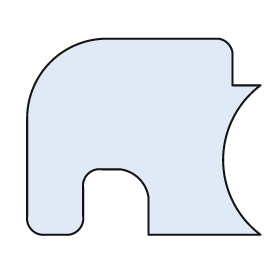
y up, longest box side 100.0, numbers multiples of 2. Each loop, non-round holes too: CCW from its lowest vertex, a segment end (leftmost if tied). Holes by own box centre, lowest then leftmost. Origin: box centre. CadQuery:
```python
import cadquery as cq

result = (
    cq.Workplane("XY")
    .moveTo(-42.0, -42.0)
    .lineTo(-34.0, -42.0)
    .threePointArc((-28.0, -40.0), (-26.0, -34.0))
    .lineTo(-26.0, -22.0)
    .threePointArc((-24.0, -16.0), (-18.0, -14.0))
    .lineTo(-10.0, -14.0)
    .threePointArc((-2.0, -18.0), (2.0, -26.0))
    .lineTo(2.0, -42.0)
    .lineTo(50.0, -42.0)
    .threePointArc((34.0, -10.0), (50.0, 22.0))
    .lineTo(38.0, 22.0)
    .lineTo(38.0, 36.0)
    .threePointArc((36.0, 40.0), (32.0, 42.0))
    .lineTo(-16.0, 42.0)
    .threePointArc((-40.0, 32.0), (-50.0, 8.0))
    .lineTo(-50.0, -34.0)
    .threePointArc((-48.0, -40.0), (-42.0, -42.0))
    .close()
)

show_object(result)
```